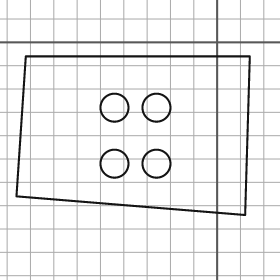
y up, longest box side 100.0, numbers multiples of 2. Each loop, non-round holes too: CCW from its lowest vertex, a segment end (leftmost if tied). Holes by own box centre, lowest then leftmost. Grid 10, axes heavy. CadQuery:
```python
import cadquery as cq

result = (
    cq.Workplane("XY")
    .moveTo(12.0, -74.0)
    .lineTo(14.0, -6.0)
    .lineTo(-82.0, -6.0)
    .lineTo(-86.0, -66.0)
    .close()
    .moveTo(-44.0, -52.0)
    .circle(6.0)
    .moveTo(-26.0, -52.0)
    .circle(6.0)
    .moveTo(-44.0, -28.0)
    .circle(6.0)
    .moveTo(-26.0, -28.0)
    .circle(6.0)
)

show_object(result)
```